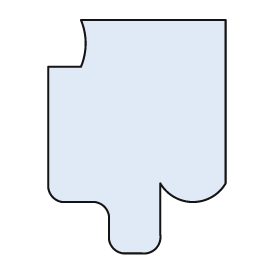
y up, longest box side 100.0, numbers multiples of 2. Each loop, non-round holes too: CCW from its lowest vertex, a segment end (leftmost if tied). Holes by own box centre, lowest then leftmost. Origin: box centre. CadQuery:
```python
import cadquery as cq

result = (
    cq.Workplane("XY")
    .moveTo(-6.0, -50.0)
    .lineTo(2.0, -50.0)
    .threePointArc((8.0, -48.0), (10.0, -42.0))
    .lineTo(10.0, -20.0)
    .threePointArc((24.0, -28.0), (38.0, -20.0))
    .lineTo(38.0, 50.0)
    .lineTo(-24.0, 50.0)
    .threePointArc((-22.0, 40.0), (-24.0, 30.0))
    .lineTo(-38.0, 30.0)
    .lineTo(-38.0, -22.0)
    .threePointArc((-36.0, -26.0), (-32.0, -28.0))
    .lineTo(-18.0, -28.0)
    .threePointArc((-14.0, -30.0), (-12.0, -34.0))
    .lineTo(-12.0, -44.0)
    .threePointArc((-10.0, -48.0), (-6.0, -50.0))
    .close()
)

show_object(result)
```